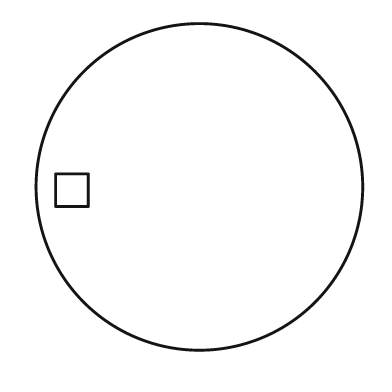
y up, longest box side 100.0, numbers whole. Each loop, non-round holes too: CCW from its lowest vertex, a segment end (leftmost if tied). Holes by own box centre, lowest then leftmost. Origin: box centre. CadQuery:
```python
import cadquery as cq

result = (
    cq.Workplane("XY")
    .moveTo(0.0, 0.0)
    .circle(50.0)
    .moveTo(-44.0, -6.0)
    .lineTo(-34.0, -6.0)
    .lineTo(-34.0, 4.0)
    .lineTo(-44.0, 4.0)
    .close()
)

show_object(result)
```